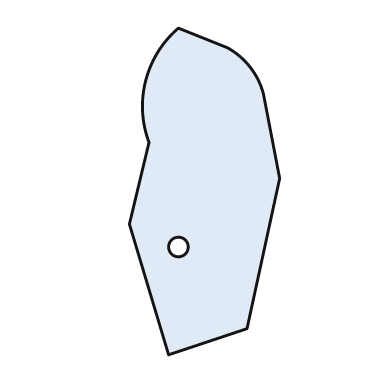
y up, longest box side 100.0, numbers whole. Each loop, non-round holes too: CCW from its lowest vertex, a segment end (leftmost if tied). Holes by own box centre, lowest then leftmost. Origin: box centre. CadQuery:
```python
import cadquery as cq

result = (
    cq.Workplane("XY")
    .moveTo(-11.0, -50.0)
    .lineTo(13.0, -42.0)
    .lineTo(23.0, 4.0)
    .lineTo(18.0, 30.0)
    .threePointArc((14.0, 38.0), (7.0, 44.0))
    .lineTo(-8.0, 50.0)
    .threePointArc((-18.0, 34.0), (-17.0, 15.0))
    .lineTo(-23.0, -10.0)
    .close()
    .moveTo(-8.0, -17.0)
    .circle(3.0)
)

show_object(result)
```